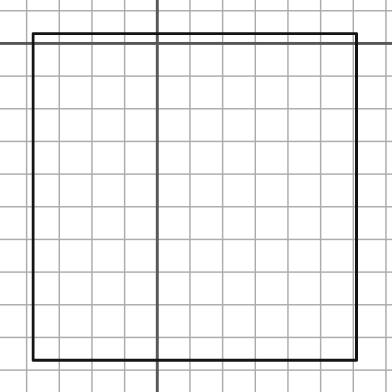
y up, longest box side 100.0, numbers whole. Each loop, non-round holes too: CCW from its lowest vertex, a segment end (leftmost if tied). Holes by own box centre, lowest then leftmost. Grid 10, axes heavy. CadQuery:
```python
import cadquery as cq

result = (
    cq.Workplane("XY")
    .moveTo(-38.0, -97.0)
    .lineTo(61.0, -97.0)
    .lineTo(61.0, 3.0)
    .lineTo(-38.0, 3.0)
    .close()
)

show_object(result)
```